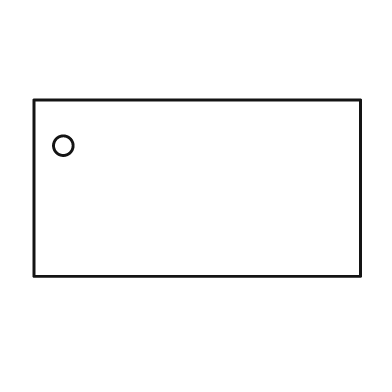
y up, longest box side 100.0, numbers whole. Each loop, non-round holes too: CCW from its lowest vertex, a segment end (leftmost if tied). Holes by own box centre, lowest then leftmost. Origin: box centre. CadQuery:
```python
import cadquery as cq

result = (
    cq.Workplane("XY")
    .moveTo(-50.0, -27.0)
    .lineTo(50.0, -27.0)
    .lineTo(50.0, 27.0)
    .lineTo(-50.0, 27.0)
    .close()
    .moveTo(-41.0, 13.0)
    .circle(3.0)
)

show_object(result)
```